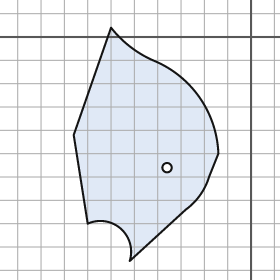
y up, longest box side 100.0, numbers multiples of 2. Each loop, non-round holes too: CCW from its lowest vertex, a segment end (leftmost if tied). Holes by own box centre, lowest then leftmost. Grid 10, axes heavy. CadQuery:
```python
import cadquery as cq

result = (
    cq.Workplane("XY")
    .moveTo(-52.0, -96.0)
    .lineTo(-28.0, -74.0)
    .threePointArc((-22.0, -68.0), (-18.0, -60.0))
    .lineTo(-14.0, -50.0)
    .threePointArc((-22.0, -26.0), (-42.0, -10.0))
    .threePointArc((-52.0, -4.0), (-60.0, 4.0))
    .lineTo(-76.0, -42.0)
    .lineTo(-70.0, -80.0)
    .threePointArc((-56.0, -82.0), (-52.0, -96.0))
    .close()
    .moveTo(-36.0, -56.0)
    .circle(2.0)
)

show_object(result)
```